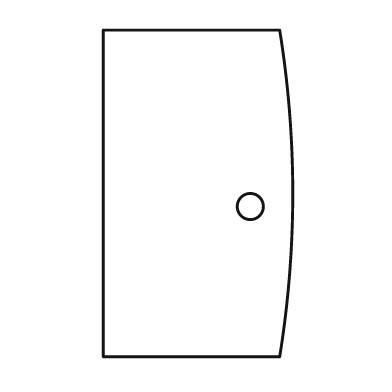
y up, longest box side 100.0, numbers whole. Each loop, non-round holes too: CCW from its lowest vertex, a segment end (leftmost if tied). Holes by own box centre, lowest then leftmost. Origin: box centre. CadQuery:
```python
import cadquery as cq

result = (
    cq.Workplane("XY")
    .moveTo(-29.0, -50.0)
    .lineTo(25.0, -50.0)
    .threePointArc((29.0, 0.0), (25.0, 50.0))
    .lineTo(-29.0, 50.0)
    .close()
    .moveTo(16.0, -4.0)
    .circle(4.0)
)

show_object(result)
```